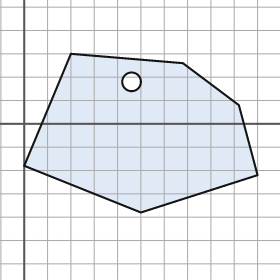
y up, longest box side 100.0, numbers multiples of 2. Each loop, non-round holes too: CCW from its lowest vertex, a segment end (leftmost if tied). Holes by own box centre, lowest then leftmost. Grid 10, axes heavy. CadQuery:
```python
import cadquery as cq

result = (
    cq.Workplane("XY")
    .moveTo(50.0, -38.0)
    .lineTo(100.0, -22.0)
    .lineTo(92.0, 8.0)
    .lineTo(68.0, 26.0)
    .lineTo(20.0, 30.0)
    .lineTo(0.0, -18.0)
    .close()
    .moveTo(46.0, 18.0)
    .circle(4.0)
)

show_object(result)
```